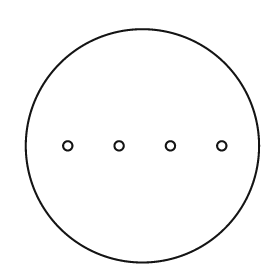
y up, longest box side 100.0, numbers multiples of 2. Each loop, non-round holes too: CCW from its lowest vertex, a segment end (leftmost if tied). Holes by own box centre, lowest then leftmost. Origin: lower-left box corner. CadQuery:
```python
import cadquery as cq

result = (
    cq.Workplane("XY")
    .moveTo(50.0, 50.0)
    .circle(50.0)
    .moveTo(18.0, 50.0)
    .circle(2.0)
    .moveTo(40.0, 50.0)
    .circle(2.0)
    .moveTo(62.0, 50.0)
    .circle(2.0)
    .moveTo(84.0, 50.0)
    .circle(2.0)
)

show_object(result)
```